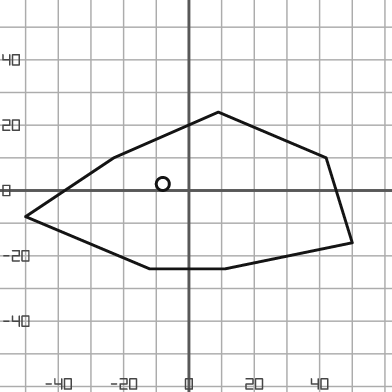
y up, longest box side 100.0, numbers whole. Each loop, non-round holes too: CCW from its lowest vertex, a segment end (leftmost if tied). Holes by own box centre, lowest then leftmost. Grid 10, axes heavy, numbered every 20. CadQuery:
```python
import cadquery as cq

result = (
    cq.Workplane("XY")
    .moveTo(-12.0, -24.0)
    .lineTo(11.0, -24.0)
    .lineTo(50.0, -16.0)
    .lineTo(42.0, 10.0)
    .lineTo(9.0, 24.0)
    .lineTo(-23.0, 10.0)
    .lineTo(-50.0, -8.0)
    .close()
    .moveTo(-8.0, 2.0)
    .circle(2.0)
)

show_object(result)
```